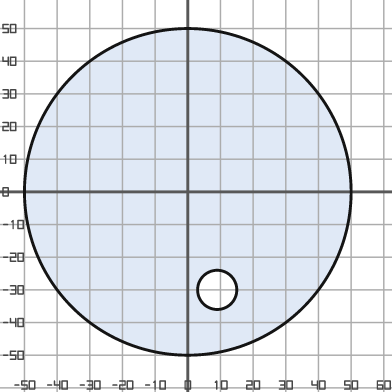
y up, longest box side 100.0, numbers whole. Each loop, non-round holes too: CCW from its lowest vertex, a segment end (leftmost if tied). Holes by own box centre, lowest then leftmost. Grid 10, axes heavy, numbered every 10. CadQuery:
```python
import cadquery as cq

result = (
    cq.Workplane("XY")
    .moveTo(0.0, 0.0)
    .circle(50.0)
    .moveTo(9.0, -30.0)
    .circle(6.0)
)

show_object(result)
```